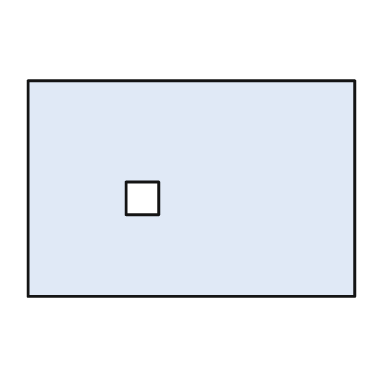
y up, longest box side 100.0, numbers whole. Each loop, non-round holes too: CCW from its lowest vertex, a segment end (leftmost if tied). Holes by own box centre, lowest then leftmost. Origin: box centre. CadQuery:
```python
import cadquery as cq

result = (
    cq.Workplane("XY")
    .moveTo(-50.0, -33.0)
    .lineTo(50.0, -33.0)
    .lineTo(50.0, 33.0)
    .lineTo(-50.0, 33.0)
    .close()
    .moveTo(-20.0, -8.0)
    .lineTo(-10.0, -8.0)
    .lineTo(-10.0, 2.0)
    .lineTo(-20.0, 2.0)
    .close()
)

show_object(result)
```